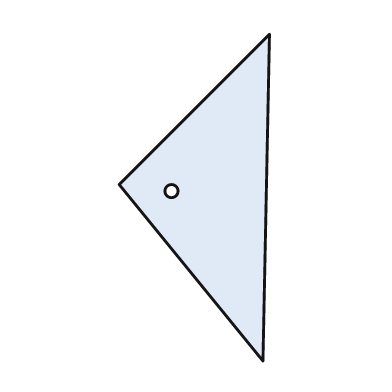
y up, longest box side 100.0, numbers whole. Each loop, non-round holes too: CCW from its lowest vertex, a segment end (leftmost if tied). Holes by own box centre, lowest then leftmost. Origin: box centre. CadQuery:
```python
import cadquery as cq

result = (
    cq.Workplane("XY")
    .moveTo(21.0, -50.0)
    .lineTo(23.0, 50.0)
    .lineTo(-23.0, 4.0)
    .close()
    .moveTo(-7.0, 2.0)
    .circle(2.0)
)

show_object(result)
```